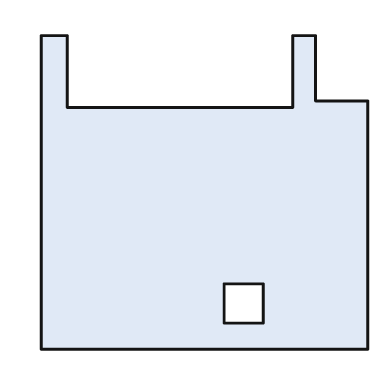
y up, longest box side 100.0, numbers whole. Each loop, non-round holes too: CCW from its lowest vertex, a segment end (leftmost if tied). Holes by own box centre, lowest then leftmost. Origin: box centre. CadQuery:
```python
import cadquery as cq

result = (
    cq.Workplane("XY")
    .moveTo(-50.0, -48.0)
    .lineTo(50.0, -48.0)
    .lineTo(50.0, 28.0)
    .lineTo(34.0, 28.0)
    .lineTo(34.0, 48.0)
    .lineTo(27.0, 48.0)
    .lineTo(27.0, 26.0)
    .lineTo(-42.0, 26.0)
    .lineTo(-42.0, 48.0)
    .lineTo(-50.0, 48.0)
    .close()
    .moveTo(6.0, -40.0)
    .lineTo(18.0, -40.0)
    .lineTo(18.0, -28.0)
    .lineTo(6.0, -28.0)
    .close()
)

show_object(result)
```